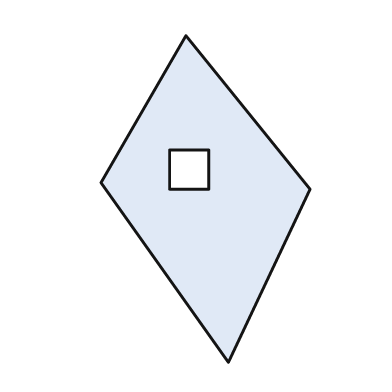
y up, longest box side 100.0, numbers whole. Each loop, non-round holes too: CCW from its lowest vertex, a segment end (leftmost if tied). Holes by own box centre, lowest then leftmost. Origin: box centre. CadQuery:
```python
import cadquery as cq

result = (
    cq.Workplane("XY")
    .moveTo(7.0, -50.0)
    .lineTo(32.0, 3.0)
    .lineTo(-6.0, 50.0)
    .lineTo(-32.0, 5.0)
    .close()
    .moveTo(-11.0, 3.0)
    .lineTo(1.0, 3.0)
    .lineTo(1.0, 15.0)
    .lineTo(-11.0, 15.0)
    .close()
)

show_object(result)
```